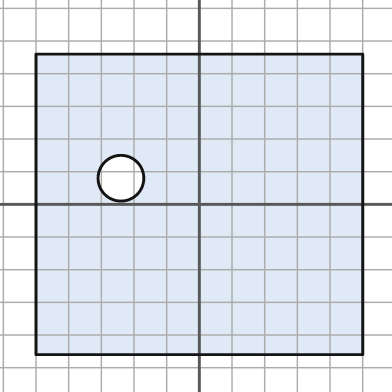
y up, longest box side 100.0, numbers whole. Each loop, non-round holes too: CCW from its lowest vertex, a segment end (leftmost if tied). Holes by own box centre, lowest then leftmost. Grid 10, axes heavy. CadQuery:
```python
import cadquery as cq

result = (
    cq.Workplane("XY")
    .moveTo(-50.0, -46.0)
    .lineTo(50.0, -46.0)
    .lineTo(50.0, 46.0)
    .lineTo(-50.0, 46.0)
    .close()
    .moveTo(-24.0, 8.0)
    .circle(7.0)
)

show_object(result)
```